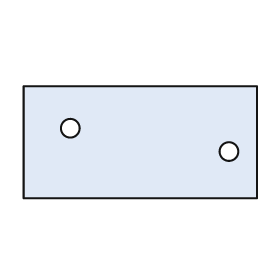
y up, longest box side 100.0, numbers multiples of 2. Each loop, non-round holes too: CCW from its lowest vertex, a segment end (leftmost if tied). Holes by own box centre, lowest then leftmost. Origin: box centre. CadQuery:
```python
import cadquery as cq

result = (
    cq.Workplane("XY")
    .moveTo(-50.0, -24.0)
    .lineTo(50.0, -24.0)
    .lineTo(50.0, 24.0)
    .lineTo(-50.0, 24.0)
    .close()
    .moveTo(38.0, -4.0)
    .circle(4.0)
    .moveTo(-30.0, 6.0)
    .circle(4.0)
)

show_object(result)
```